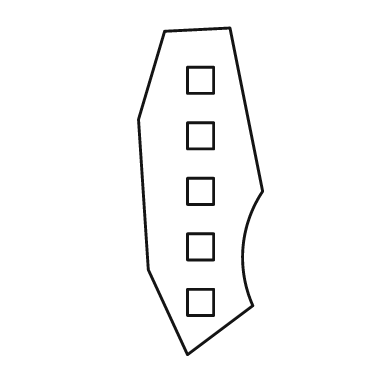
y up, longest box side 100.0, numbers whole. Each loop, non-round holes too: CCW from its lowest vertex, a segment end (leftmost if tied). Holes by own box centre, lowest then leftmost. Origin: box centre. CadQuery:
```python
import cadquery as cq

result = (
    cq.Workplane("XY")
    .moveTo(-4.0, -50.0)
    .lineTo(16.0, -35.0)
    .threePointArc((13.0, -17.0), (19.0, 0.0))
    .lineTo(9.0, 50.0)
    .lineTo(-11.0, 49.0)
    .lineTo(-19.0, 22.0)
    .lineTo(-16.0, -24.0)
    .close()
    .moveTo(-4.0, -38.0)
    .lineTo(4.0, -38.0)
    .lineTo(4.0, -30.0)
    .lineTo(-4.0, -30.0)
    .close()
    .moveTo(-4.0, -21.0)
    .lineTo(4.0, -21.0)
    .lineTo(4.0, -13.0)
    .lineTo(-4.0, -13.0)
    .close()
    .moveTo(-4.0, -4.0)
    .lineTo(4.0, -4.0)
    .lineTo(4.0, 4.0)
    .lineTo(-4.0, 4.0)
    .close()
    .moveTo(-4.0, 13.0)
    .lineTo(4.0, 13.0)
    .lineTo(4.0, 21.0)
    .lineTo(-4.0, 21.0)
    .close()
    .moveTo(-4.0, 30.0)
    .lineTo(4.0, 30.0)
    .lineTo(4.0, 38.0)
    .lineTo(-4.0, 38.0)
    .close()
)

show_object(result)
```